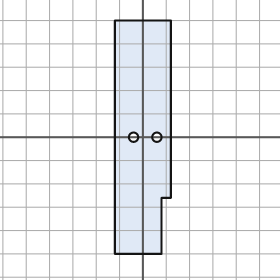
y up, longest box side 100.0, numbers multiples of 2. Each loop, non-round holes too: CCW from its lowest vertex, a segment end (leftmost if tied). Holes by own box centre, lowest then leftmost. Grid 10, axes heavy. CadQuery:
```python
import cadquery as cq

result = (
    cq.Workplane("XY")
    .moveTo(-12.0, -50.0)
    .lineTo(8.0, -50.0)
    .lineTo(8.0, -26.0)
    .lineTo(12.0, -26.0)
    .lineTo(12.0, 50.0)
    .lineTo(-12.0, 50.0)
    .close()
    .moveTo(-4.0, 0.0)
    .circle(2.0)
    .moveTo(6.0, 0.0)
    .circle(2.0)
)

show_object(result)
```